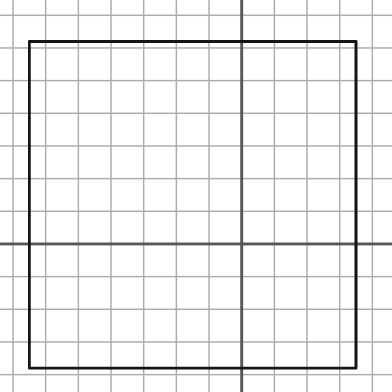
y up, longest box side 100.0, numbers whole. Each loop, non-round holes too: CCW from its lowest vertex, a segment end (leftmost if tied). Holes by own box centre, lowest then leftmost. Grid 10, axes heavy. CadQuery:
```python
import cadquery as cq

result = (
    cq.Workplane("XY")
    .moveTo(-65.0, -38.0)
    .lineTo(35.0, -38.0)
    .lineTo(35.0, 62.0)
    .lineTo(-65.0, 62.0)
    .close()
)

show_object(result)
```